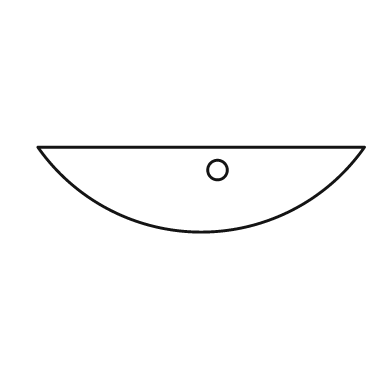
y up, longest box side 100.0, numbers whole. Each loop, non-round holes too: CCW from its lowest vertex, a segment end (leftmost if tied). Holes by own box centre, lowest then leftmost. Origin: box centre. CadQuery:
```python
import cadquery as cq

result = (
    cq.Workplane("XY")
    .moveTo(-50.0, 13.0)
    .threePointArc((0.0, -13.0), (50.0, 13.0))
    .close()
    .moveTo(5.0, 6.0)
    .circle(3.0)
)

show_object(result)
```